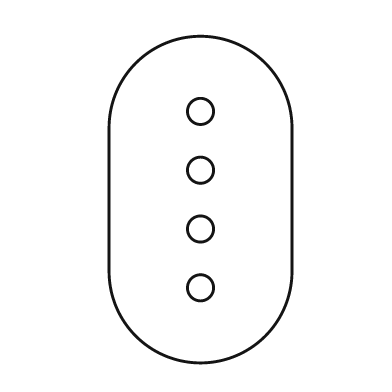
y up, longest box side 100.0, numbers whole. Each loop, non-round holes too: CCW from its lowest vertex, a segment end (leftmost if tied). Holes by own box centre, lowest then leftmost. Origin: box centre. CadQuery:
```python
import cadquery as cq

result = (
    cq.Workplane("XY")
    .moveTo(-28.0, -22.0)
    .threePointArc((0.0, -50.0), (28.0, -22.0))
    .lineTo(28.0, 22.0)
    .threePointArc((0.0, 50.0), (-28.0, 22.0))
    .close()
    .moveTo(0.0, -27.0)
    .circle(4.0)
    .moveTo(0.0, -9.0)
    .circle(4.0)
    .moveTo(0.0, 9.0)
    .circle(4.0)
    .moveTo(0.0, 27.0)
    .circle(4.0)
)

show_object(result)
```